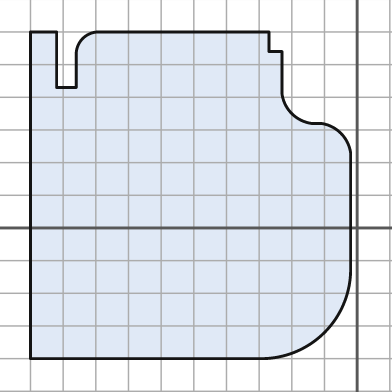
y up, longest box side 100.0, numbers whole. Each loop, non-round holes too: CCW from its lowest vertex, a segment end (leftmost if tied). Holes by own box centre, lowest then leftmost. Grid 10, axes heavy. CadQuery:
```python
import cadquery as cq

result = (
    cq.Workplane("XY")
    .moveTo(-100.0, -40.0)
    .lineTo(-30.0, -40.0)
    .threePointArc((-10.0, -32.0), (-2.0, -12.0))
    .lineTo(-2.0, 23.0)
    .threePointArc((-5.0, 29.0), (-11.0, 32.0))
    .lineTo(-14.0, 32.0)
    .threePointArc((-20.0, 35.0), (-23.0, 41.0))
    .lineTo(-23.0, 54.0)
    .lineTo(-27.0, 54.0)
    .lineTo(-27.0, 60.0)
    .lineTo(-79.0, 60.0)
    .threePointArc((-84.0, 58.0), (-86.0, 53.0))
    .lineTo(-86.0, 43.0)
    .lineTo(-92.0, 43.0)
    .lineTo(-92.0, 60.0)
    .lineTo(-100.0, 60.0)
    .close()
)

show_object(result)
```